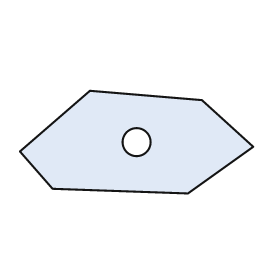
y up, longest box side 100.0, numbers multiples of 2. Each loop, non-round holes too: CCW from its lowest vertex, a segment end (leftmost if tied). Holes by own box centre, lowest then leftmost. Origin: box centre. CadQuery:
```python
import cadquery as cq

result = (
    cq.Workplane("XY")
    .moveTo(22.0, -22.0)
    .lineTo(50.0, -2.0)
    .lineTo(28.0, 18.0)
    .lineTo(-20.0, 22.0)
    .lineTo(-50.0, -4.0)
    .lineTo(-36.0, -20.0)
    .close()
    .moveTo(0.0, 0.0)
    .circle(6.0)
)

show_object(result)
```